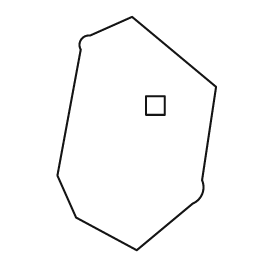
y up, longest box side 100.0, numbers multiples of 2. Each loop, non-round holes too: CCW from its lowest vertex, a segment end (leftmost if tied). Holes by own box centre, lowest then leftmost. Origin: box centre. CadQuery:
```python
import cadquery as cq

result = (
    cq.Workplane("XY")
    .moveTo(0.0, -50.0)
    .lineTo(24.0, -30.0)
    .threePointArc((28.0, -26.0), (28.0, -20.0))
    .lineTo(34.0, 20.0)
    .lineTo(-2.0, 50.0)
    .lineTo(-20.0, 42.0)
    .threePointArc((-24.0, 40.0), (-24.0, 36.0))
    .lineTo(-34.0, -18.0)
    .lineTo(-26.0, -36.0)
    .close()
    .moveTo(4.0, 8.0)
    .lineTo(12.0, 8.0)
    .lineTo(12.0, 16.0)
    .lineTo(4.0, 16.0)
    .close()
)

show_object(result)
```